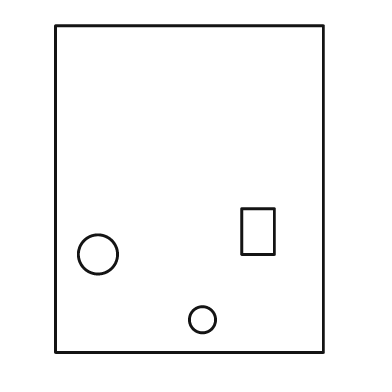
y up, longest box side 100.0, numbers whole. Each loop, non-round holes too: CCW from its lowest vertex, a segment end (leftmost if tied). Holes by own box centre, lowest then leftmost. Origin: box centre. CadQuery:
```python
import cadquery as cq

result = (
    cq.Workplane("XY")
    .moveTo(-41.0, -50.0)
    .lineTo(41.0, -50.0)
    .lineTo(41.0, 50.0)
    .lineTo(-41.0, 50.0)
    .close()
    .moveTo(4.0, -40.0)
    .circle(4.0)
    .moveTo(-28.0, -20.0)
    .circle(6.0)
    .moveTo(16.0, -20.0)
    .lineTo(26.0, -20.0)
    .lineTo(26.0, -6.0)
    .lineTo(16.0, -6.0)
    .close()
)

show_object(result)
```